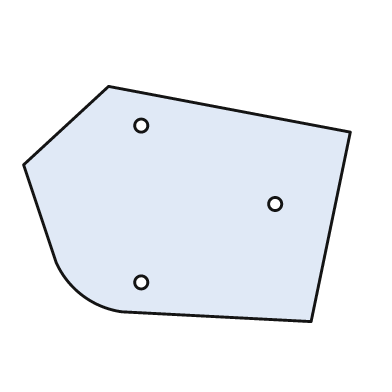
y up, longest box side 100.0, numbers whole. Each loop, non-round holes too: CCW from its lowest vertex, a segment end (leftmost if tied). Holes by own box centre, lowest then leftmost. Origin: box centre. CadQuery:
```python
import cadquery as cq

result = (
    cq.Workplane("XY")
    .moveTo(38.0, -36.0)
    .lineTo(50.0, 22.0)
    .lineTo(-24.0, 36.0)
    .lineTo(-50.0, 12.0)
    .lineTo(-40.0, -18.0)
    .threePointArc((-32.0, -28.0), (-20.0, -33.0))
    .close()
    .moveTo(-14.0, -24.0)
    .circle(2.0)
    .moveTo(27.0, 0.0)
    .circle(2.0)
    .moveTo(-14.0, 24.0)
    .circle(2.0)
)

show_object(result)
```